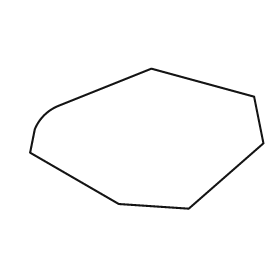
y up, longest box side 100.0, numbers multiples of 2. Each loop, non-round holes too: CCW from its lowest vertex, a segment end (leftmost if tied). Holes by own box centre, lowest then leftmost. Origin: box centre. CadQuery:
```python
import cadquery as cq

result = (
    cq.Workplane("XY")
    .moveTo(18.0, -30.0)
    .lineTo(50.0, -2.0)
    .lineTo(46.0, 18.0)
    .lineTo(2.0, 30.0)
    .lineTo(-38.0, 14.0)
    .threePointArc((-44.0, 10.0), (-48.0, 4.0))
    .lineTo(-50.0, -6.0)
    .lineTo(-12.0, -28.0)
    .close()
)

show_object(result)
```